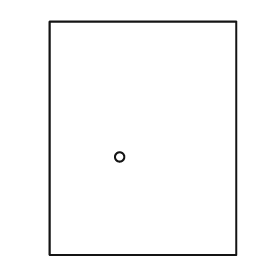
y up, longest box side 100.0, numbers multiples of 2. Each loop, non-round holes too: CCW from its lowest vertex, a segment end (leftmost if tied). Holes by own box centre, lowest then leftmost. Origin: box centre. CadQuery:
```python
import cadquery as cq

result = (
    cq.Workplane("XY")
    .moveTo(-40.0, -50.0)
    .lineTo(40.0, -50.0)
    .lineTo(40.0, 50.0)
    .lineTo(-40.0, 50.0)
    .close()
    .moveTo(-10.0, -8.0)
    .circle(2.0)
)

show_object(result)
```